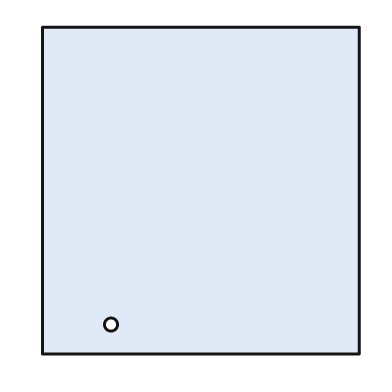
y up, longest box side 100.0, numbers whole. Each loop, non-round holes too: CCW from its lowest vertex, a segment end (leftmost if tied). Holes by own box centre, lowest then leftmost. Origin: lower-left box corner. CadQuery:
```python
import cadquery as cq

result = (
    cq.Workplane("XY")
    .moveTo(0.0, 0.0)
    .lineTo(97.0, 0.0)
    .lineTo(97.0, 100.0)
    .lineTo(0.0, 100.0)
    .close()
    .moveTo(21.0, 9.0)
    .circle(2.0)
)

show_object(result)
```